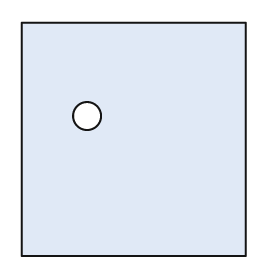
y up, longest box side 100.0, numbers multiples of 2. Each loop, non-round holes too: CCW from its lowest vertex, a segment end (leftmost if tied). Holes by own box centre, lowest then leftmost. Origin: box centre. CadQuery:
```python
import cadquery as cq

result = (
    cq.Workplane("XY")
    .moveTo(-48.0, -50.0)
    .lineTo(48.0, -50.0)
    .lineTo(48.0, 50.0)
    .lineTo(-48.0, 50.0)
    .close()
    .moveTo(-20.0, 10.0)
    .circle(6.0)
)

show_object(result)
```